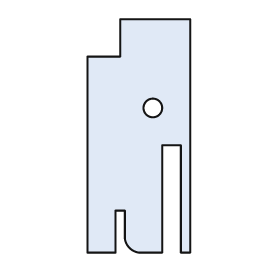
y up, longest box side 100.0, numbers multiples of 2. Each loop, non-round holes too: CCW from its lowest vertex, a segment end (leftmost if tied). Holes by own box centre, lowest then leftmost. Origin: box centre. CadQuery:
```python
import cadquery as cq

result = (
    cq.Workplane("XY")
    .moveTo(-22.0, -50.0)
    .lineTo(-10.0, -50.0)
    .lineTo(-10.0, -32.0)
    .lineTo(-6.0, -32.0)
    .lineTo(-6.0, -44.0)
    .threePointArc((-4.0, -48.0), (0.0, -50.0))
    .lineTo(10.0, -50.0)
    .lineTo(10.0, -4.0)
    .lineTo(18.0, -4.0)
    .lineTo(18.0, -50.0)
    .lineTo(22.0, -50.0)
    .lineTo(22.0, 50.0)
    .lineTo(-8.0, 50.0)
    .lineTo(-8.0, 34.0)
    .lineTo(-22.0, 34.0)
    .close()
    .moveTo(6.0, 12.0)
    .circle(4.0)
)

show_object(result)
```